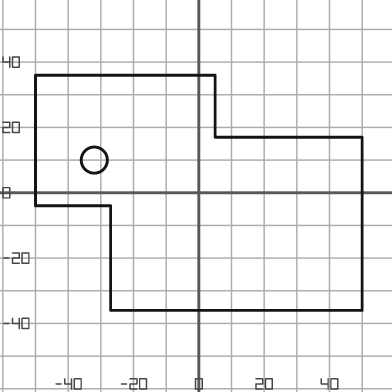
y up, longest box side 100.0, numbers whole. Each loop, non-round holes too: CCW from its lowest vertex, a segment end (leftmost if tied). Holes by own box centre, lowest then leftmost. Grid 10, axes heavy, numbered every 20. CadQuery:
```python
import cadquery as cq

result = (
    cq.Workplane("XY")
    .moveTo(-27.0, -36.0)
    .lineTo(50.0, -36.0)
    .lineTo(50.0, 17.0)
    .lineTo(5.0, 17.0)
    .lineTo(5.0, 36.0)
    .lineTo(-50.0, 36.0)
    .lineTo(-50.0, -4.0)
    .lineTo(-27.0, -4.0)
    .close()
    .moveTo(-32.0, 10.0)
    .circle(4.0)
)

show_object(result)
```